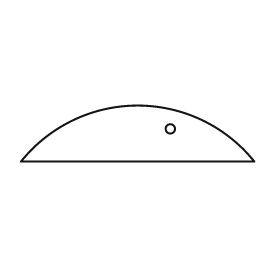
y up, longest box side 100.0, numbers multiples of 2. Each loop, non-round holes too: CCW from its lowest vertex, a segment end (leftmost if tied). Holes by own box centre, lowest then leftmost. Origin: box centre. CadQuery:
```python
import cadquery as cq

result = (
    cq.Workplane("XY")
    .moveTo(-50.0, -12.0)
    .lineTo(50.0, -12.0)
    .threePointArc((0.0, 12.0), (-50.0, -12.0))
    .close()
    .moveTo(14.0, 2.0)
    .circle(2.0)
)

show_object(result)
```